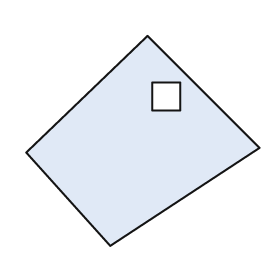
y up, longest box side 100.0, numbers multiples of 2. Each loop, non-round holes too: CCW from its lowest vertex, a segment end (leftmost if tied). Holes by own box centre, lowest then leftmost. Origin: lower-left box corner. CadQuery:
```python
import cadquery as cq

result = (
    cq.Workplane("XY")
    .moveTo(36.0, 0.0)
    .lineTo(100.0, 42.0)
    .lineTo(52.0, 90.0)
    .lineTo(0.0, 40.0)
    .close()
    .moveTo(54.0, 58.0)
    .lineTo(66.0, 58.0)
    .lineTo(66.0, 70.0)
    .lineTo(54.0, 70.0)
    .close()
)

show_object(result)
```